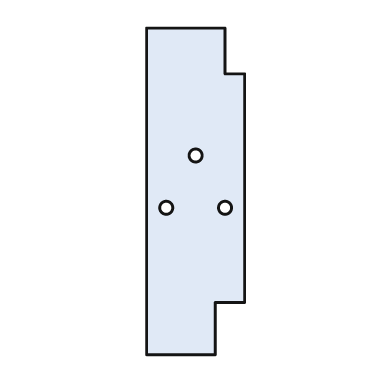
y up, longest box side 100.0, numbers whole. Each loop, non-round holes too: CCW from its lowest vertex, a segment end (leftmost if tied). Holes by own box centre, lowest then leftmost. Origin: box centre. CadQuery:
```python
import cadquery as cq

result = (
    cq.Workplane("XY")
    .moveTo(-15.0, -50.0)
    .lineTo(6.0, -50.0)
    .lineTo(6.0, -34.0)
    .lineTo(15.0, -34.0)
    .lineTo(15.0, 36.0)
    .lineTo(9.0, 36.0)
    .lineTo(9.0, 50.0)
    .lineTo(-15.0, 50.0)
    .close()
    .moveTo(-9.0, -5.0)
    .circle(2.0)
    .moveTo(9.0, -5.0)
    .circle(2.0)
    .moveTo(0.0, 11.0)
    .circle(2.0)
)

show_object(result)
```